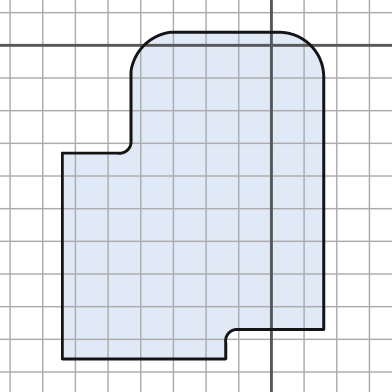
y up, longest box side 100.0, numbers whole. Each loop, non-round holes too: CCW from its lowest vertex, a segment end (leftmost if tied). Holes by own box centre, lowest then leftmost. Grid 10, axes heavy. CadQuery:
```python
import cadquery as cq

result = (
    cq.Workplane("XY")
    .moveTo(-64.0, -96.0)
    .lineTo(-14.0, -96.0)
    .lineTo(-14.0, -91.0)
    .threePointArc((-13.0, -88.0), (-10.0, -87.0))
    .lineTo(16.0, -87.0)
    .lineTo(16.0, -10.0)
    .threePointArc((12.0, 0.0), (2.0, 4.0))
    .lineTo(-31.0, 4.0)
    .threePointArc((-39.0, 0.0), (-43.0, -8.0))
    .lineTo(-43.0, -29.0)
    .threePointArc((-44.0, -32.0), (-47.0, -33.0))
    .lineTo(-64.0, -33.0)
    .close()
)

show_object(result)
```